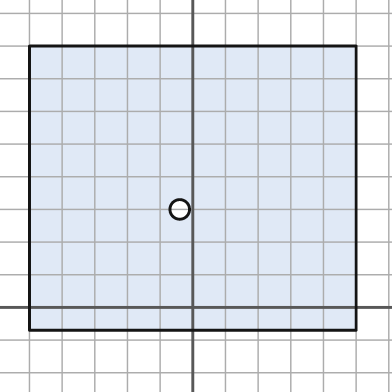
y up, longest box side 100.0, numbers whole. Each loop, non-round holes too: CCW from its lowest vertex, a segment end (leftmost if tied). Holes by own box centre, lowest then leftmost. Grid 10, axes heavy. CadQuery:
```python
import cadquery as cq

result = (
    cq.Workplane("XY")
    .moveTo(-50.0, -7.0)
    .lineTo(50.0, -7.0)
    .lineTo(50.0, 80.0)
    .lineTo(-50.0, 80.0)
    .close()
    .moveTo(-4.0, 30.0)
    .circle(3.0)
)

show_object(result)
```